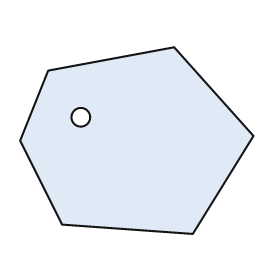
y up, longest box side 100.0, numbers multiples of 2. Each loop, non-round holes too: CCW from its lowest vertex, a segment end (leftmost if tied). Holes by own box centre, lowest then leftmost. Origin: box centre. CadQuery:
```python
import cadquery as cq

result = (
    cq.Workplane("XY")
    .moveTo(24.0, -40.0)
    .lineTo(50.0, 2.0)
    .lineTo(16.0, 40.0)
    .lineTo(-38.0, 30.0)
    .lineTo(-50.0, 0.0)
    .lineTo(-32.0, -36.0)
    .close()
    .moveTo(-24.0, 10.0)
    .circle(4.0)
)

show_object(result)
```